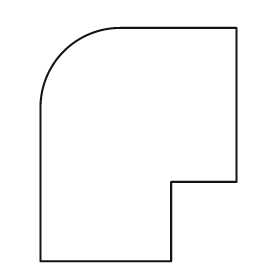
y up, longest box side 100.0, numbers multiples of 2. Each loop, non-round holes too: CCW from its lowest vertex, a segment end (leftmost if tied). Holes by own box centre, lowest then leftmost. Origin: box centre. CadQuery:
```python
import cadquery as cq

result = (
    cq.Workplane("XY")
    .moveTo(-42.0, -50.0)
    .lineTo(14.0, -50.0)
    .lineTo(14.0, -16.0)
    .lineTo(42.0, -16.0)
    .lineTo(42.0, 50.0)
    .lineTo(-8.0, 50.0)
    .threePointArc((-32.0, 40.0), (-42.0, 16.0))
    .close()
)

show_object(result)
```